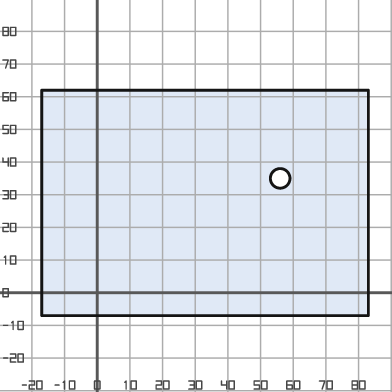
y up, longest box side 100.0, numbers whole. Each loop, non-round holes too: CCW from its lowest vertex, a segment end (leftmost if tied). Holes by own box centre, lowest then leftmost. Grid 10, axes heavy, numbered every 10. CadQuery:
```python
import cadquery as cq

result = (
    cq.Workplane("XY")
    .moveTo(-17.0, -7.0)
    .lineTo(83.0, -7.0)
    .lineTo(83.0, 62.0)
    .lineTo(-17.0, 62.0)
    .close()
    .moveTo(56.0, 35.0)
    .circle(3.0)
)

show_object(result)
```